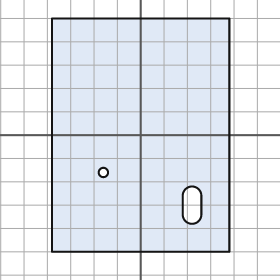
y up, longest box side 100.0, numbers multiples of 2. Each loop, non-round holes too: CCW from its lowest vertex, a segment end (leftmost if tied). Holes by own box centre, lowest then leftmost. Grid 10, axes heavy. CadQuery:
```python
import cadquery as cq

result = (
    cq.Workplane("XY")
    .moveTo(-38.0, -50.0)
    .lineTo(38.0, -50.0)
    .lineTo(38.0, 50.0)
    .lineTo(-38.0, 50.0)
    .close()
    .moveTo(18.0, -34.0)
    .threePointArc((22.0, -38.0), (26.0, -34.0))
    .lineTo(26.0, -26.0)
    .threePointArc((22.0, -22.0), (18.0, -26.0))
    .close()
    .moveTo(-16.0, -16.0)
    .circle(2.0)
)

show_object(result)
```